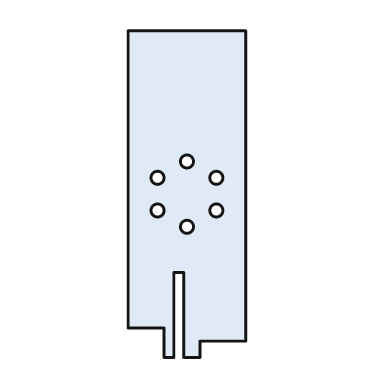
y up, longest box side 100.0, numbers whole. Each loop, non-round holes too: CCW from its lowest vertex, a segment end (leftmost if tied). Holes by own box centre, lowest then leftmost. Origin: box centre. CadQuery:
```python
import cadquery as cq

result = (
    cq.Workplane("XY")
    .moveTo(-7.0, -50.0)
    .lineTo(-4.0, -50.0)
    .lineTo(-4.0, -24.0)
    .lineTo(-1.0, -24.0)
    .lineTo(-1.0, -50.0)
    .lineTo(4.0, -50.0)
    .lineTo(4.0, -45.0)
    .lineTo(18.0, -45.0)
    .lineTo(18.0, 50.0)
    .lineTo(-18.0, 50.0)
    .lineTo(-18.0, -41.0)
    .lineTo(-7.0, -41.0)
    .close()
    .moveTo(0.0, -10.0)
    .circle(2.0)
    .moveTo(-9.0, -5.0)
    .circle(2.0)
    .moveTo(9.0, -5.0)
    .circle(2.0)
    .moveTo(-9.0, 5.0)
    .circle(2.0)
    .moveTo(9.0, 5.0)
    .circle(2.0)
    .moveTo(0.0, 10.0)
    .circle(2.0)
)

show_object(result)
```